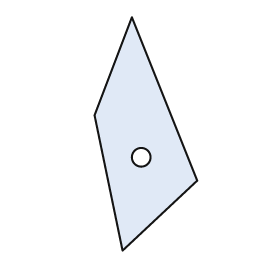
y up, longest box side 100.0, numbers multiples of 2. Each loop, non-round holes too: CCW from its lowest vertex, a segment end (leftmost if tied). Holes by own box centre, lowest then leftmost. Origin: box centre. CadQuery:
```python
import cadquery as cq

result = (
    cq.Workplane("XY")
    .moveTo(-10.0, -50.0)
    .lineTo(22.0, -20.0)
    .lineTo(-6.0, 50.0)
    .lineTo(-22.0, 8.0)
    .close()
    .moveTo(-2.0, -10.0)
    .circle(4.0)
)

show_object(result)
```